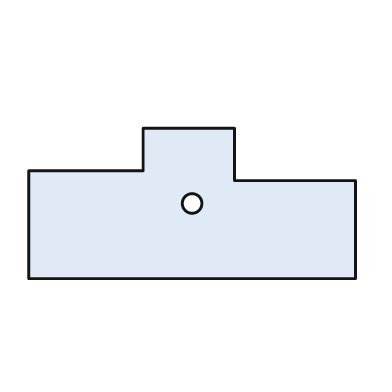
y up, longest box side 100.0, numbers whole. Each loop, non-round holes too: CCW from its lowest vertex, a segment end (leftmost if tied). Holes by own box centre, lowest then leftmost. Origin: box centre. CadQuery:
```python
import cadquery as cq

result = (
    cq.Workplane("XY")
    .moveTo(-50.0, -23.0)
    .lineTo(50.0, -23.0)
    .lineTo(50.0, 7.0)
    .lineTo(13.0, 7.0)
    .lineTo(13.0, 23.0)
    .lineTo(-15.0, 23.0)
    .lineTo(-15.0, 10.0)
    .lineTo(-50.0, 10.0)
    .close()
    .moveTo(0.0, 0.0)
    .circle(3.0)
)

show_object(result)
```